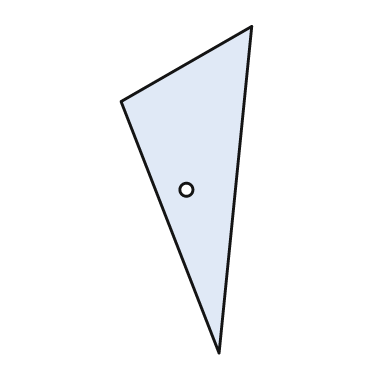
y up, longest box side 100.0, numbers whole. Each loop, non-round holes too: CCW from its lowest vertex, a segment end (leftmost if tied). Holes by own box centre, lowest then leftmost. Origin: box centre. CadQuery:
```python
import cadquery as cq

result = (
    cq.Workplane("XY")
    .moveTo(10.0, -50.0)
    .lineTo(20.0, 50.0)
    .lineTo(-20.0, 27.0)
    .close()
    .moveTo(0.0, 0.0)
    .circle(2.0)
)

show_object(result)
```